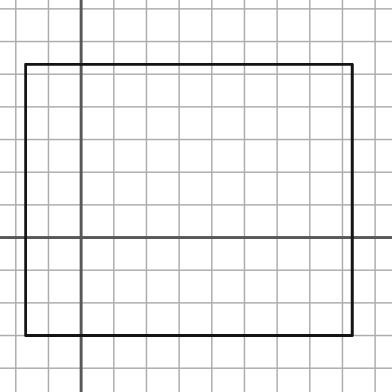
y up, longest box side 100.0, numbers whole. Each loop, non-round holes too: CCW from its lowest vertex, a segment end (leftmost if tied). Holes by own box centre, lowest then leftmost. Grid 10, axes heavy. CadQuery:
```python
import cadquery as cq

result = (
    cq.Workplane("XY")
    .moveTo(-17.0, -30.0)
    .lineTo(83.0, -30.0)
    .lineTo(83.0, 53.0)
    .lineTo(-17.0, 53.0)
    .close()
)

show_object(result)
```